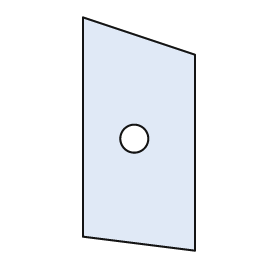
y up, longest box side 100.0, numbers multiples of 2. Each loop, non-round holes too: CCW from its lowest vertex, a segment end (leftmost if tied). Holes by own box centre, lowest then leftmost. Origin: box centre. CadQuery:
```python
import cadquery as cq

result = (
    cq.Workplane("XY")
    .moveTo(24.0, -50.0)
    .lineTo(24.0, 34.0)
    .lineTo(-24.0, 50.0)
    .lineTo(-24.0, -44.0)
    .close()
    .moveTo(-2.0, -2.0)
    .circle(6.0)
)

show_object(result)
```